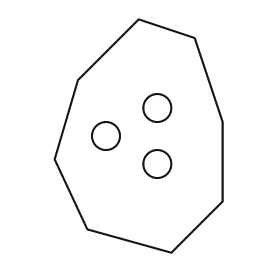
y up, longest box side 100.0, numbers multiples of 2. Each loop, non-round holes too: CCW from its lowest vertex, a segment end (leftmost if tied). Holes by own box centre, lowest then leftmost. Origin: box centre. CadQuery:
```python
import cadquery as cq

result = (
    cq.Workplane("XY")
    .moveTo(14.0, -50.0)
    .lineTo(36.0, -28.0)
    .lineTo(36.0, 6.0)
    .lineTo(24.0, 42.0)
    .lineTo(0.0, 50.0)
    .lineTo(-26.0, 24.0)
    .lineTo(-36.0, -10.0)
    .lineTo(-22.0, -40.0)
    .close()
    .moveTo(8.0, -12.0)
    .circle(6.0)
    .moveTo(-14.0, 0.0)
    .circle(6.0)
    .moveTo(8.0, 12.0)
    .circle(6.0)
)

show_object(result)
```